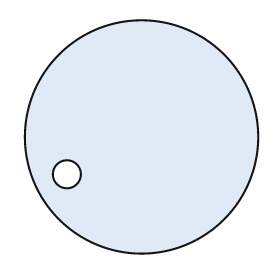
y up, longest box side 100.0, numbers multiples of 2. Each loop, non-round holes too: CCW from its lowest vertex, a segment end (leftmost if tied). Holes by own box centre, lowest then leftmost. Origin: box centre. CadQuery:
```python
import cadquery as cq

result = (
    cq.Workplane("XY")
    .moveTo(0.0, 0.0)
    .circle(50.0)
    .moveTo(-32.0, -16.0)
    .circle(6.0)
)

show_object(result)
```